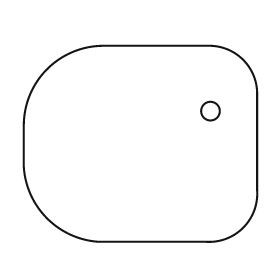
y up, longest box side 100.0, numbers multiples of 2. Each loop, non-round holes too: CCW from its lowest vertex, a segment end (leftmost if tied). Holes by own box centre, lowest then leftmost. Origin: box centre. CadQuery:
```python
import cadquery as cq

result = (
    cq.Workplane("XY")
    .moveTo(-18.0, -42.0)
    .lineTo(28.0, -42.0)
    .threePointArc((44.0, -36.0), (50.0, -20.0))
    .lineTo(50.0, 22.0)
    .threePointArc((44.0, 36.0), (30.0, 42.0))
    .lineTo(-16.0, 42.0)
    .threePointArc((-40.0, 32.0), (-50.0, 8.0))
    .lineTo(-50.0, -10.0)
    .threePointArc((-40.0, -32.0), (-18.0, -42.0))
    .close()
    .moveTo(30.0, 14.0)
    .circle(4.0)
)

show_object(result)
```